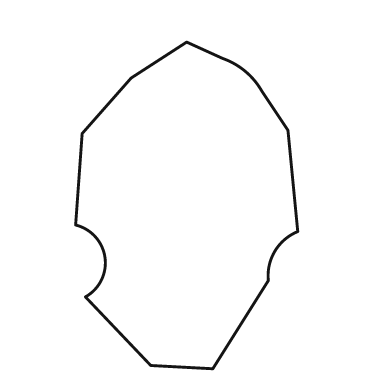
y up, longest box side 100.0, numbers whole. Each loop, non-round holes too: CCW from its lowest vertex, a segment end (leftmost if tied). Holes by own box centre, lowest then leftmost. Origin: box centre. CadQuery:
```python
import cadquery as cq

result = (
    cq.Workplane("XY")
    .moveTo(8.0, -50.0)
    .lineTo(25.0, -23.0)
    .threePointArc((27.0, -14.0), (34.0, -8.0))
    .lineTo(31.0, 23.0)
    .lineTo(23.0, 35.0)
    .threePointArc((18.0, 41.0), (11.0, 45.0))
    .lineTo(0.0, 50.0)
    .lineTo(-17.0, 39.0)
    .lineTo(-32.0, 22.0)
    .lineTo(-34.0, -6.0)
    .threePointArc((-25.0, -16.0), (-31.0, -28.0))
    .lineTo(-11.0, -49.0)
    .close()
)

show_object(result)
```